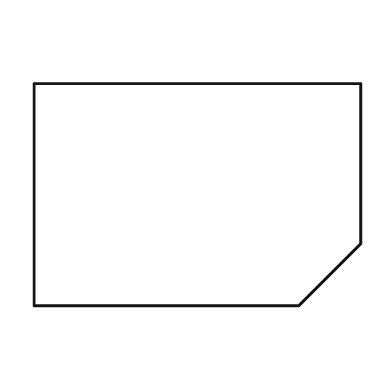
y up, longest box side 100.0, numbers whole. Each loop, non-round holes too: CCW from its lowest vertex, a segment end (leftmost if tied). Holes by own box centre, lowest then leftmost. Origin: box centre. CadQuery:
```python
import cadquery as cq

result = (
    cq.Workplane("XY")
    .moveTo(-50.0, -34.0)
    .lineTo(31.0, -34.0)
    .lineTo(50.0, -15.0)
    .lineTo(50.0, 34.0)
    .lineTo(-50.0, 34.0)
    .close()
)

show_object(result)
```